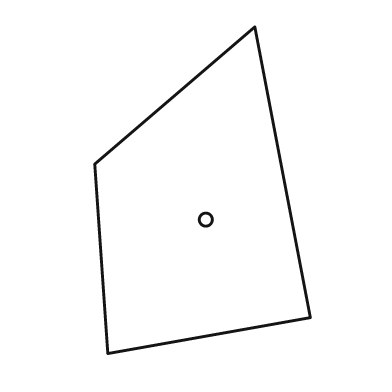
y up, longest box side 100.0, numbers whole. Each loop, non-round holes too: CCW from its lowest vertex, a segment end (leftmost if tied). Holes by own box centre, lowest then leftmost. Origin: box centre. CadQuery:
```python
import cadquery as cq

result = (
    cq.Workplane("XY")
    .moveTo(-29.0, -50.0)
    .lineTo(33.0, -39.0)
    .lineTo(16.0, 50.0)
    .lineTo(-33.0, 8.0)
    .close()
    .moveTo(1.0, -9.0)
    .circle(2.0)
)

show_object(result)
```